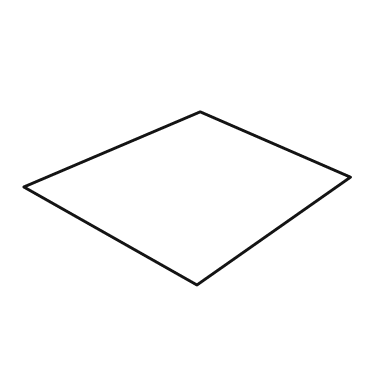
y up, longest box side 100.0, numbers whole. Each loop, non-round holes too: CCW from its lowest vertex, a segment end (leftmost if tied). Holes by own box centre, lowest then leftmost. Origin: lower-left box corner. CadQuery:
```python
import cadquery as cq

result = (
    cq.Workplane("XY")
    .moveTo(53.0, 0.0)
    .lineTo(100.0, 33.0)
    .lineTo(54.0, 53.0)
    .lineTo(0.0, 30.0)
    .close()
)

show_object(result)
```